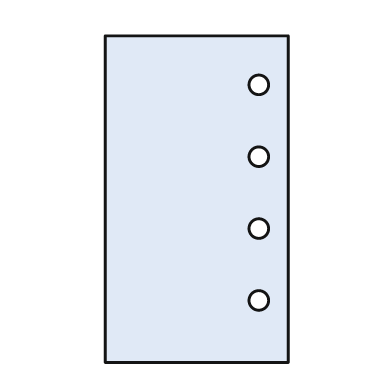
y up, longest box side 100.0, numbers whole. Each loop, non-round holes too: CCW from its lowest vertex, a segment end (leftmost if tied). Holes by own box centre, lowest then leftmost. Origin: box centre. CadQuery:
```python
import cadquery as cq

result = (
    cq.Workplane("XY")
    .moveTo(-28.0, -50.0)
    .lineTo(28.0, -50.0)
    .lineTo(28.0, 50.0)
    .lineTo(-28.0, 50.0)
    .close()
    .moveTo(19.0, -31.0)
    .circle(3.0)
    .moveTo(19.0, -9.0)
    .circle(3.0)
    .moveTo(19.0, 13.0)
    .circle(3.0)
    .moveTo(19.0, 35.0)
    .circle(3.0)
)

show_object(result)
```